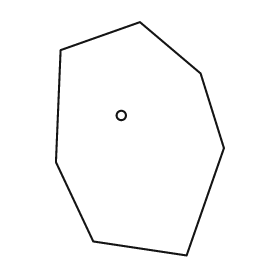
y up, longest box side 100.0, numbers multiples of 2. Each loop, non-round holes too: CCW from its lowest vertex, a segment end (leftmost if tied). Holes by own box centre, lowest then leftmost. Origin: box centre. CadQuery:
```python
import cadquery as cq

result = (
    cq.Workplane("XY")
    .moveTo(20.0, -50.0)
    .lineTo(36.0, -4.0)
    .lineTo(26.0, 28.0)
    .lineTo(0.0, 50.0)
    .lineTo(-34.0, 38.0)
    .lineTo(-36.0, -10.0)
    .lineTo(-20.0, -44.0)
    .close()
    .moveTo(-8.0, 10.0)
    .circle(2.0)
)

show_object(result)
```